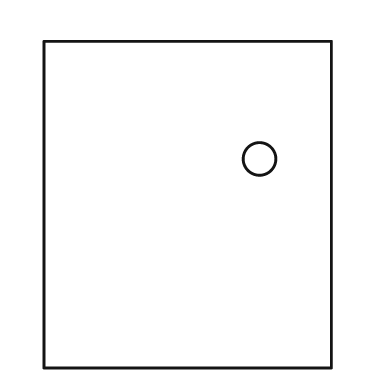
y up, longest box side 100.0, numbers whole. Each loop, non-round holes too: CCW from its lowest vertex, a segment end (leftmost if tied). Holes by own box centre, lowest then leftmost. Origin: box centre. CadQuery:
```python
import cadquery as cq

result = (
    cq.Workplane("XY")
    .moveTo(-44.0, -50.0)
    .lineTo(44.0, -50.0)
    .lineTo(44.0, 50.0)
    .lineTo(-44.0, 50.0)
    .close()
    .moveTo(22.0, 14.0)
    .circle(5.0)
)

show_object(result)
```